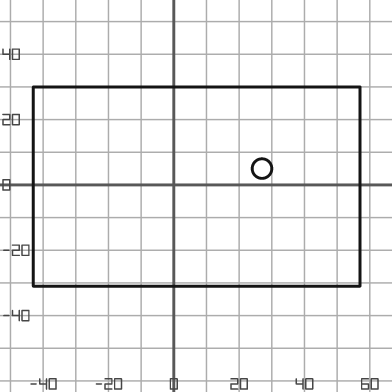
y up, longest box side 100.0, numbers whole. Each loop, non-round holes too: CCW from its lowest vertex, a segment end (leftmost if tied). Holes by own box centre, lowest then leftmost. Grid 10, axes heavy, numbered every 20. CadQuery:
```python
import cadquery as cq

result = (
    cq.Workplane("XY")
    .moveTo(-43.0, -31.0)
    .lineTo(57.0, -31.0)
    .lineTo(57.0, 30.0)
    .lineTo(-43.0, 30.0)
    .close()
    .moveTo(27.0, 5.0)
    .circle(3.0)
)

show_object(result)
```